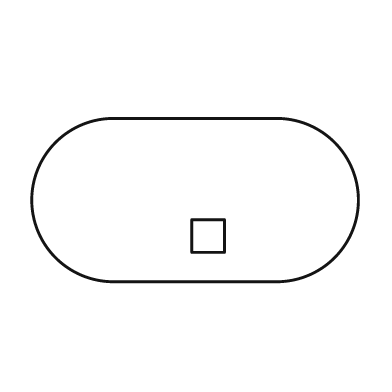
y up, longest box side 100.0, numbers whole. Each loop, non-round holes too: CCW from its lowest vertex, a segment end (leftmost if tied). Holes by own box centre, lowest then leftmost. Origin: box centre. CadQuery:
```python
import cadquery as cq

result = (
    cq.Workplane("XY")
    .moveTo(-25.0, -25.0)
    .lineTo(25.0, -25.0)
    .threePointArc((50.0, 0.0), (25.0, 25.0))
    .lineTo(-25.0, 25.0)
    .threePointArc((-50.0, 0.0), (-25.0, -25.0))
    .close()
    .moveTo(-1.0, -16.0)
    .lineTo(9.0, -16.0)
    .lineTo(9.0, -6.0)
    .lineTo(-1.0, -6.0)
    .close()
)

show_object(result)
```